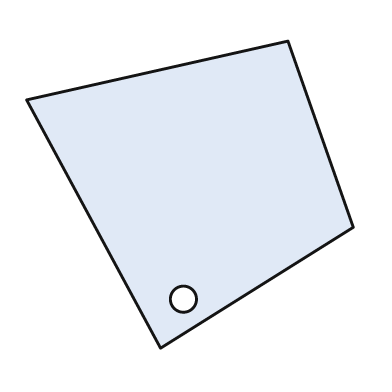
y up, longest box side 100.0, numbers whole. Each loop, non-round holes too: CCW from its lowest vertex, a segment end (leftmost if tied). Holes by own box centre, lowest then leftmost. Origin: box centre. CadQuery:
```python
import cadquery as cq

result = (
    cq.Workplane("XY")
    .moveTo(-9.0, -47.0)
    .lineTo(50.0, -10.0)
    .lineTo(30.0, 47.0)
    .lineTo(-50.0, 29.0)
    .close()
    .moveTo(-2.0, -32.0)
    .circle(4.0)
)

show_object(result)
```